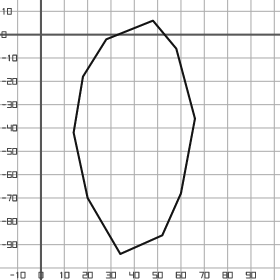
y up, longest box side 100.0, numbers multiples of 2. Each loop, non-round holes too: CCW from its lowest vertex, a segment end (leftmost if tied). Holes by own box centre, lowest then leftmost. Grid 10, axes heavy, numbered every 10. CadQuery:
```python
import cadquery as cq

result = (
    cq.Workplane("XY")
    .moveTo(34.0, -94.0)
    .lineTo(52.0, -86.0)
    .lineTo(60.0, -68.0)
    .lineTo(66.0, -36.0)
    .lineTo(58.0, -6.0)
    .lineTo(48.0, 6.0)
    .lineTo(28.0, -2.0)
    .lineTo(18.0, -18.0)
    .lineTo(14.0, -42.0)
    .lineTo(20.0, -70.0)
    .close()
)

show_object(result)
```